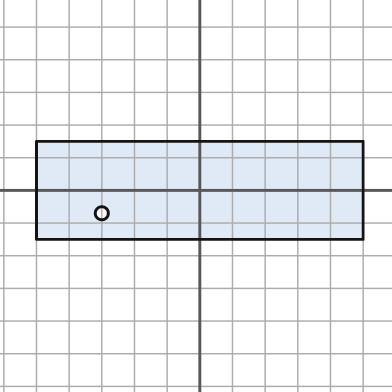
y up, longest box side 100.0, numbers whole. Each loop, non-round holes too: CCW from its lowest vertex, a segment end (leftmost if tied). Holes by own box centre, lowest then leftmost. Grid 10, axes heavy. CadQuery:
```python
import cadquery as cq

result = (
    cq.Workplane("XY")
    .moveTo(-50.0, -15.0)
    .lineTo(50.0, -15.0)
    .lineTo(50.0, 15.0)
    .lineTo(-50.0, 15.0)
    .close()
    .moveTo(-30.0, -7.0)
    .circle(2.0)
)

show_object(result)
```